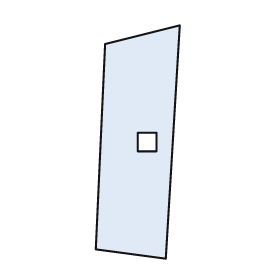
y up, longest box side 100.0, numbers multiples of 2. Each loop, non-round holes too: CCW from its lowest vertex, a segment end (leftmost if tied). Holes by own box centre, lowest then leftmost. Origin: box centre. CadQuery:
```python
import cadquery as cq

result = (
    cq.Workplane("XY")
    .moveTo(12.0, -50.0)
    .lineTo(18.0, 50.0)
    .lineTo(-14.0, 42.0)
    .lineTo(-18.0, -46.0)
    .close()
    .moveTo(0.0, -4.0)
    .lineTo(8.0, -4.0)
    .lineTo(8.0, 4.0)
    .lineTo(0.0, 4.0)
    .close()
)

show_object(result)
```